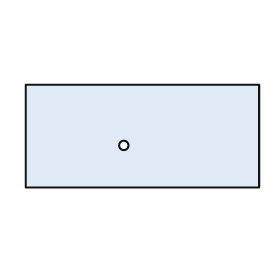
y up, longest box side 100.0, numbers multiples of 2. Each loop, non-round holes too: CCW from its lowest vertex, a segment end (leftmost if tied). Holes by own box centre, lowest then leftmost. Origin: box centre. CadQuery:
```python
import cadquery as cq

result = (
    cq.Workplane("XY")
    .moveTo(-50.0, -22.0)
    .lineTo(50.0, -22.0)
    .lineTo(50.0, 22.0)
    .lineTo(-50.0, 22.0)
    .close()
    .moveTo(-8.0, -4.0)
    .circle(2.0)
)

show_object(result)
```